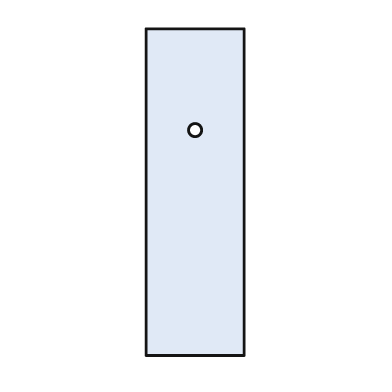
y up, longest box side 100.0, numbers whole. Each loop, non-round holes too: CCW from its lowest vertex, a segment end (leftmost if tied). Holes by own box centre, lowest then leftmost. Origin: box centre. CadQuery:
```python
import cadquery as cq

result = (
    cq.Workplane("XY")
    .moveTo(-15.0, -50.0)
    .lineTo(15.0, -50.0)
    .lineTo(15.0, 50.0)
    .lineTo(-15.0, 50.0)
    .close()
    .moveTo(0.0, 19.0)
    .circle(2.0)
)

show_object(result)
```